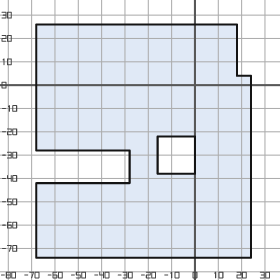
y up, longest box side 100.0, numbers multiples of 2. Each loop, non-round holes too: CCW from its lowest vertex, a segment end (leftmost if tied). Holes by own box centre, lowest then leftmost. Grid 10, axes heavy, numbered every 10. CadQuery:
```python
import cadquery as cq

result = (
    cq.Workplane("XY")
    .moveTo(-68.0, -74.0)
    .lineTo(24.0, -74.0)
    .lineTo(24.0, 4.0)
    .lineTo(18.0, 4.0)
    .lineTo(18.0, 26.0)
    .lineTo(-68.0, 26.0)
    .lineTo(-68.0, -28.0)
    .lineTo(-28.0, -28.0)
    .lineTo(-28.0, -42.0)
    .lineTo(-68.0, -42.0)
    .close()
    .moveTo(-16.0, -38.0)
    .lineTo(0.0, -38.0)
    .lineTo(0.0, -22.0)
    .lineTo(-16.0, -22.0)
    .close()
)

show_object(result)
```